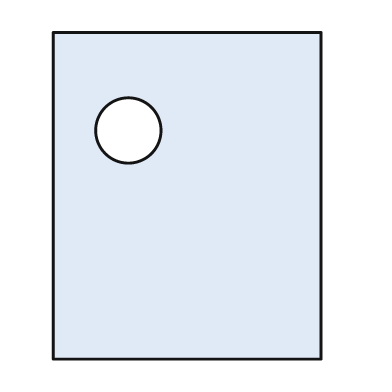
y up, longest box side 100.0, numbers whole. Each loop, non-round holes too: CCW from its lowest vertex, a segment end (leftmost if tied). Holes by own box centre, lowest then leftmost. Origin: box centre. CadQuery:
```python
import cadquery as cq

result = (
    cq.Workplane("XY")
    .moveTo(-41.0, -50.0)
    .lineTo(41.0, -50.0)
    .lineTo(41.0, 50.0)
    .lineTo(-41.0, 50.0)
    .close()
    .moveTo(-18.0, 20.0)
    .circle(10.0)
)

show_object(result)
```